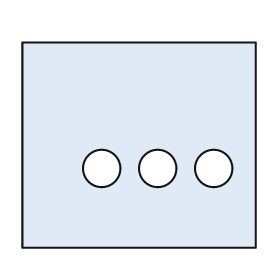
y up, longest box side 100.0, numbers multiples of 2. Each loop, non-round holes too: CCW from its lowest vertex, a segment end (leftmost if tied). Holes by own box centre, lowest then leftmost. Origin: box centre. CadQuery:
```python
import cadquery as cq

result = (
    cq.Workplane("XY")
    .moveTo(-50.0, -44.0)
    .lineTo(50.0, -44.0)
    .lineTo(50.0, 44.0)
    .lineTo(-50.0, 44.0)
    .close()
    .moveTo(-16.0, -10.0)
    .circle(8.0)
    .moveTo(8.0, -10.0)
    .circle(8.0)
    .moveTo(32.0, -10.0)
    .circle(8.0)
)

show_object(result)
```